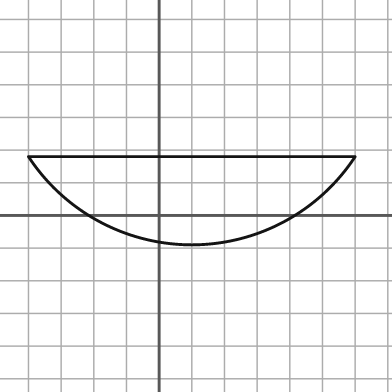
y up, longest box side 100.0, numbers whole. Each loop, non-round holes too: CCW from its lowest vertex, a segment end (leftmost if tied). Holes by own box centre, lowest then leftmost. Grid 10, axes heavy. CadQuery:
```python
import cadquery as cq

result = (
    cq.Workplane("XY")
    .moveTo(-40.0, 18.0)
    .threePointArc((10.0, -9.0), (60.0, 18.0))
    .close()
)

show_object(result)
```